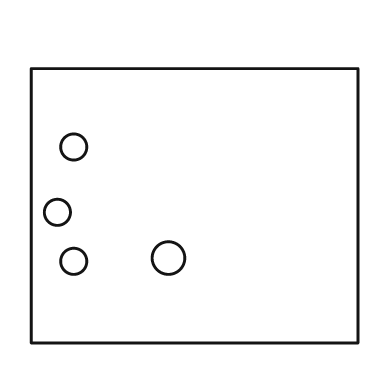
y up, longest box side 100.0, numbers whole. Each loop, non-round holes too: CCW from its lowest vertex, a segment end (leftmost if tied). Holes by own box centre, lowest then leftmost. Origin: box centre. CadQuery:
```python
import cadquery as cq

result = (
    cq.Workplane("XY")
    .moveTo(-50.0, -42.0)
    .lineTo(50.0, -42.0)
    .lineTo(50.0, 42.0)
    .lineTo(-50.0, 42.0)
    .close()
    .moveTo(-37.0, -17.0)
    .circle(4.0)
    .moveTo(-8.0, -16.0)
    .circle(5.0)
    .moveTo(-42.0, -2.0)
    .circle(4.0)
    .moveTo(-37.0, 18.0)
    .circle(4.0)
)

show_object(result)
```